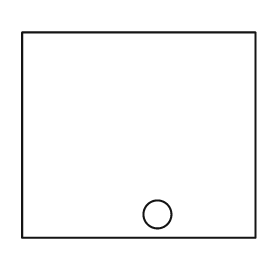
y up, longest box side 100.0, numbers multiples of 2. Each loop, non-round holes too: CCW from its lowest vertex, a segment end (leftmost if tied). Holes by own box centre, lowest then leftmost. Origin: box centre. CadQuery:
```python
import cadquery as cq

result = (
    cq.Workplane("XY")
    .moveTo(-50.0, -44.0)
    .lineTo(50.0, -44.0)
    .lineTo(50.0, 44.0)
    .lineTo(-50.0, 44.0)
    .close()
    .moveTo(8.0, -34.0)
    .circle(6.0)
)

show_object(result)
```